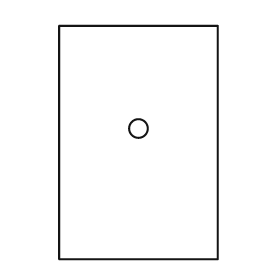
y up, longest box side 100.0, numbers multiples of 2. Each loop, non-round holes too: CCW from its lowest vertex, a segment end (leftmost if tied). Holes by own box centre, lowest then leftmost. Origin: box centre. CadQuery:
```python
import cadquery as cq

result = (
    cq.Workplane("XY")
    .moveTo(-34.0, -50.0)
    .lineTo(34.0, -50.0)
    .lineTo(34.0, 50.0)
    .lineTo(-34.0, 50.0)
    .close()
    .moveTo(0.0, 6.0)
    .circle(4.0)
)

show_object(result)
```